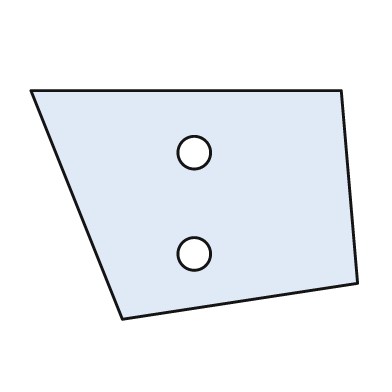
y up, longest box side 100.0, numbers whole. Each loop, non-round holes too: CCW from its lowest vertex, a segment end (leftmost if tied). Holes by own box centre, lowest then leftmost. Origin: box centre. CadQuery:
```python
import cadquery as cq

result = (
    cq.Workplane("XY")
    .moveTo(-22.0, -35.0)
    .lineTo(50.0, -24.0)
    .lineTo(45.0, 35.0)
    .lineTo(-50.0, 35.0)
    .close()
    .moveTo(0.0, -15.0)
    .circle(5.0)
    .moveTo(0.0, 16.0)
    .circle(5.0)
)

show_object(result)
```